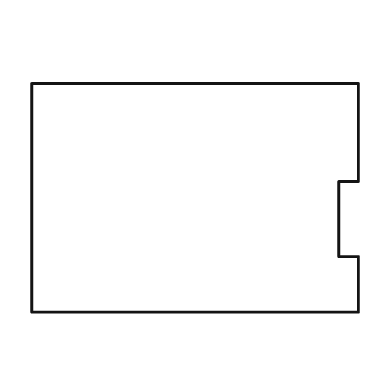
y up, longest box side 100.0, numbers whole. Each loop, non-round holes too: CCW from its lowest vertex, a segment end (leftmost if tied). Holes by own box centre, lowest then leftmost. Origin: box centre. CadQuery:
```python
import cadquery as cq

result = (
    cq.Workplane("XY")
    .moveTo(-50.0, -35.0)
    .lineTo(50.0, -35.0)
    .lineTo(50.0, -18.0)
    .lineTo(44.0, -18.0)
    .lineTo(44.0, 5.0)
    .lineTo(50.0, 5.0)
    .lineTo(50.0, 35.0)
    .lineTo(-50.0, 35.0)
    .close()
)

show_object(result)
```